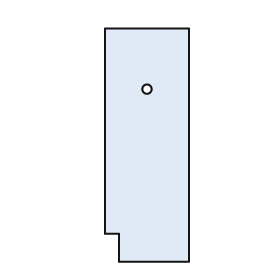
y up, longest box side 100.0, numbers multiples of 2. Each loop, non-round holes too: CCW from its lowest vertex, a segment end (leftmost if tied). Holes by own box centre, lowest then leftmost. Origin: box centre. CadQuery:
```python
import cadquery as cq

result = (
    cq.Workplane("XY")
    .moveTo(-12.0, -50.0)
    .lineTo(18.0, -50.0)
    .lineTo(18.0, 50.0)
    .lineTo(-18.0, 50.0)
    .lineTo(-18.0, -38.0)
    .lineTo(-12.0, -38.0)
    .close()
    .moveTo(0.0, 24.0)
    .circle(2.0)
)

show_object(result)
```